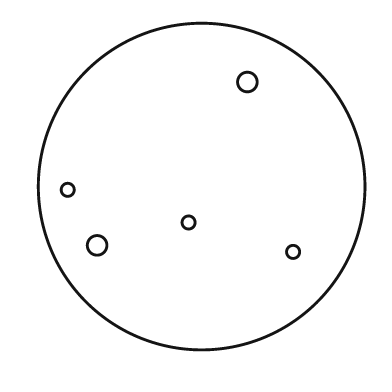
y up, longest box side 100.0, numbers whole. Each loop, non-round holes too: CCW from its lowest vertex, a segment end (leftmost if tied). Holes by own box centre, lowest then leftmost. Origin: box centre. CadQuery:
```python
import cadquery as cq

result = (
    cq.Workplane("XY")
    .moveTo(0.0, 0.0)
    .circle(50.0)
    .moveTo(28.0, -20.0)
    .circle(2.0)
    .moveTo(-32.0, -18.0)
    .circle(3.0)
    .moveTo(-4.0, -11.0)
    .circle(2.0)
    .moveTo(-41.0, -1.0)
    .circle(2.0)
    .moveTo(14.0, 32.0)
    .circle(3.0)
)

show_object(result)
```